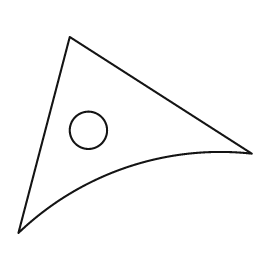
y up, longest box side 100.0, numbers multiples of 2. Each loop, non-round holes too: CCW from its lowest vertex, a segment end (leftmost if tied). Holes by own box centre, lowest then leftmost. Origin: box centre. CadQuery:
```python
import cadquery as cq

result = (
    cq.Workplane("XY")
    .moveTo(-50.0, -42.0)
    .threePointArc((-4.0, -14.0), (50.0, -8.0))
    .lineTo(-28.0, 42.0)
    .close()
    .moveTo(-20.0, 2.0)
    .circle(8.0)
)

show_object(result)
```